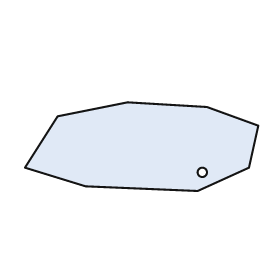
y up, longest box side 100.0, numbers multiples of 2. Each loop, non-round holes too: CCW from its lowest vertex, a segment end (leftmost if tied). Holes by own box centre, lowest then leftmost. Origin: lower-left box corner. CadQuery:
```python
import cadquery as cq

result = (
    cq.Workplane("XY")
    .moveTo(74.0, 0.0)
    .lineTo(96.0, 10.0)
    .lineTo(100.0, 28.0)
    .lineTo(78.0, 36.0)
    .lineTo(44.0, 38.0)
    .lineTo(14.0, 32.0)
    .lineTo(0.0, 10.0)
    .lineTo(26.0, 2.0)
    .close()
    .moveTo(76.0, 8.0)
    .circle(2.0)
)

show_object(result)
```